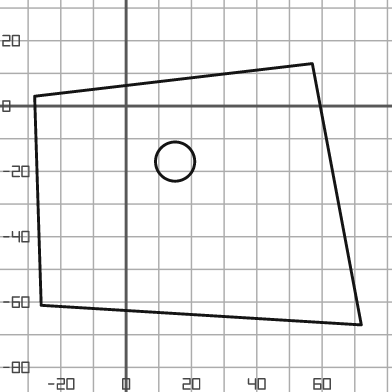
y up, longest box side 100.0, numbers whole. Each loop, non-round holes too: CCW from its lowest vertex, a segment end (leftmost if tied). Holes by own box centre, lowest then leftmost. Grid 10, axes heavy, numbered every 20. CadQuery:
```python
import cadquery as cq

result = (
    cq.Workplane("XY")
    .moveTo(72.0, -67.0)
    .lineTo(57.0, 13.0)
    .lineTo(-28.0, 3.0)
    .lineTo(-26.0, -61.0)
    .close()
    .moveTo(15.0, -17.0)
    .circle(6.0)
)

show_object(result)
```